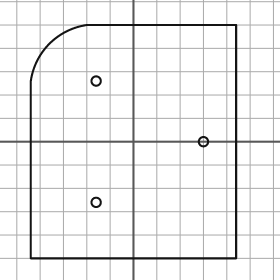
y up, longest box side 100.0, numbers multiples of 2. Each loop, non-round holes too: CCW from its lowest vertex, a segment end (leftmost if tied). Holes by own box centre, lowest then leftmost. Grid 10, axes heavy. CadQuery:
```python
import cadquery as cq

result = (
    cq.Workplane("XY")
    .moveTo(-44.0, -50.0)
    .lineTo(44.0, -50.0)
    .lineTo(44.0, 50.0)
    .lineTo(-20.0, 50.0)
    .threePointArc((-36.0, 42.0), (-44.0, 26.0))
    .close()
    .moveTo(-16.0, -26.0)
    .circle(2.0)
    .moveTo(30.0, 0.0)
    .circle(2.0)
    .moveTo(-16.0, 26.0)
    .circle(2.0)
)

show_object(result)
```